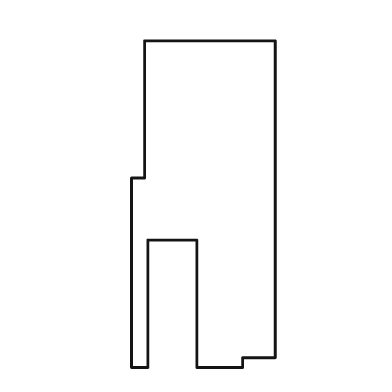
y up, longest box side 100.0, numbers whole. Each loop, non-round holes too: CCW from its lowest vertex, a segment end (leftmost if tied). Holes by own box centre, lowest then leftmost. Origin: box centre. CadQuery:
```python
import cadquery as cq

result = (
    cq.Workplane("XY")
    .moveTo(-22.0, -50.0)
    .lineTo(-17.0, -50.0)
    .lineTo(-17.0, -11.0)
    .lineTo(-2.0, -11.0)
    .lineTo(-2.0, -50.0)
    .lineTo(12.0, -50.0)
    .lineTo(12.0, -47.0)
    .lineTo(22.0, -47.0)
    .lineTo(22.0, 50.0)
    .lineTo(-18.0, 50.0)
    .lineTo(-18.0, 8.0)
    .lineTo(-22.0, 8.0)
    .close()
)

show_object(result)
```